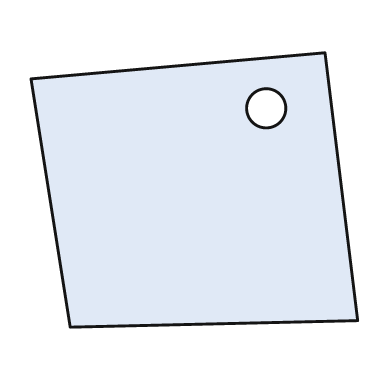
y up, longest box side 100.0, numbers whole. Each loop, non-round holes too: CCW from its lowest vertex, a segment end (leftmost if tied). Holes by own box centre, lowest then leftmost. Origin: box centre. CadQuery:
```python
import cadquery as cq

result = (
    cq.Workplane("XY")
    .moveTo(-38.0, -42.0)
    .lineTo(50.0, -40.0)
    .lineTo(40.0, 42.0)
    .lineTo(-50.0, 34.0)
    .close()
    .moveTo(22.0, 25.0)
    .circle(6.0)
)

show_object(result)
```